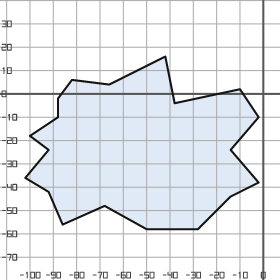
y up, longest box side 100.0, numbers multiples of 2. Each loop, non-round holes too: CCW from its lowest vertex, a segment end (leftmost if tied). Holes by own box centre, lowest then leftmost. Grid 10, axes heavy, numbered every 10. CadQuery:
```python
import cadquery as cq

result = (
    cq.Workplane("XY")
    .moveTo(-50.0, -58.0)
    .lineTo(-28.0, -58.0)
    .lineTo(-14.0, -44.0)
    .lineTo(-2.0, -38.0)
    .lineTo(-14.0, -24.0)
    .lineTo(-2.0, -10.0)
    .lineTo(-10.0, 2.0)
    .lineTo(-38.0, -4.0)
    .lineTo(-42.0, 16.0)
    .lineTo(-66.0, 4.0)
    .lineTo(-82.0, 6.0)
    .lineTo(-88.0, -2.0)
    .lineTo(-88.0, -10.0)
    .lineTo(-100.0, -18.0)
    .lineTo(-92.0, -24.0)
    .lineTo(-102.0, -36.0)
    .lineTo(-92.0, -42.0)
    .lineTo(-86.0, -56.0)
    .lineTo(-68.0, -48.0)
    .close()
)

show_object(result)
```